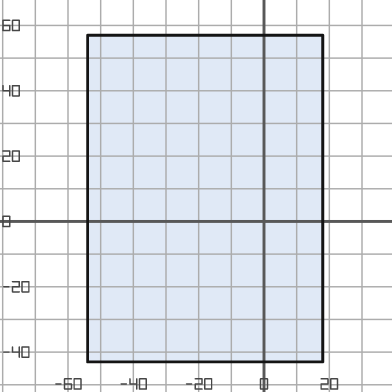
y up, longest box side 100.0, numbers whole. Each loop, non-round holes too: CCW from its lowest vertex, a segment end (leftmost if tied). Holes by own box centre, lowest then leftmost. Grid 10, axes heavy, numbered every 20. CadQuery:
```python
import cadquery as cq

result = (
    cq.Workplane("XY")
    .moveTo(-54.0, -43.0)
    .lineTo(18.0, -43.0)
    .lineTo(18.0, 57.0)
    .lineTo(-54.0, 57.0)
    .close()
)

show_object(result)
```